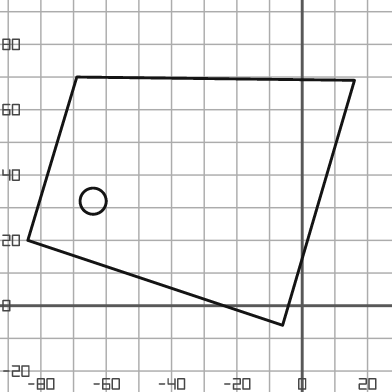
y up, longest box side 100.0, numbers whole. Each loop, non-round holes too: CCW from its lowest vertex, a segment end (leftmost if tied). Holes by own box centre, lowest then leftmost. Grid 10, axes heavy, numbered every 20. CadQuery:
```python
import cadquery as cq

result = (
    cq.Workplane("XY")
    .moveTo(-6.0, -6.0)
    .lineTo(16.0, 69.0)
    .lineTo(-69.0, 70.0)
    .lineTo(-84.0, 20.0)
    .close()
    .moveTo(-64.0, 32.0)
    .circle(4.0)
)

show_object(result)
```